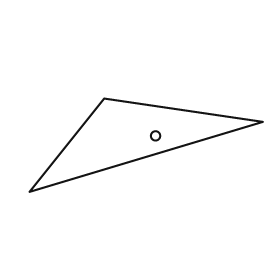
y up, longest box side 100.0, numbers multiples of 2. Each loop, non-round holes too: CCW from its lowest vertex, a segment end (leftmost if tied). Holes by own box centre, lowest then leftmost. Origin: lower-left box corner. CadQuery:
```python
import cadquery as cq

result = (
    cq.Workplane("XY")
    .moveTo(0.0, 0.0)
    .lineTo(100.0, 30.0)
    .lineTo(32.0, 40.0)
    .close()
    .moveTo(54.0, 24.0)
    .circle(2.0)
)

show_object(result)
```